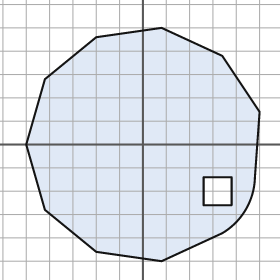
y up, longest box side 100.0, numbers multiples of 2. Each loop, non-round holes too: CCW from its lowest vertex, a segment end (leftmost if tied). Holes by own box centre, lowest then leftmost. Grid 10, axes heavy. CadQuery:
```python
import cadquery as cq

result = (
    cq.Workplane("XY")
    .moveTo(8.0, -50.0)
    .lineTo(34.0, -38.0)
    .threePointArc((44.0, -28.0), (48.0, -14.0))
    .lineTo(50.0, 14.0)
    .lineTo(34.0, 38.0)
    .lineTo(8.0, 50.0)
    .lineTo(-20.0, 46.0)
    .lineTo(-42.0, 28.0)
    .lineTo(-50.0, 0.0)
    .lineTo(-42.0, -28.0)
    .lineTo(-20.0, -46.0)
    .close()
    .moveTo(26.0, -26.0)
    .lineTo(38.0, -26.0)
    .lineTo(38.0, -14.0)
    .lineTo(26.0, -14.0)
    .close()
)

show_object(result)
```